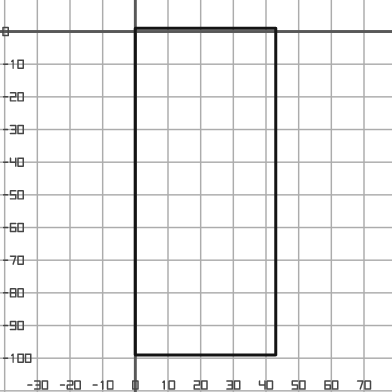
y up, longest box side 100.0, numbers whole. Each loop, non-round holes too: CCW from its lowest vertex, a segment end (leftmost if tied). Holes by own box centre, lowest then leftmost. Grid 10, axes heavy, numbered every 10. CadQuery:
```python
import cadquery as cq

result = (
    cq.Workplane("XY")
    .moveTo(0.0, -99.0)
    .lineTo(43.0, -99.0)
    .lineTo(43.0, 1.0)
    .lineTo(0.0, 1.0)
    .close()
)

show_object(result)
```